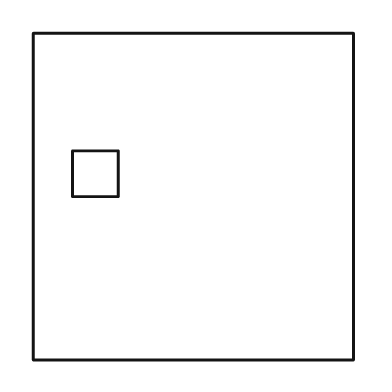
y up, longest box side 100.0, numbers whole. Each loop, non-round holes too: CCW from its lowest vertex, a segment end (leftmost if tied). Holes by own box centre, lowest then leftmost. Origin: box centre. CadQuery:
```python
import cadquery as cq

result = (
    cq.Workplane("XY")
    .moveTo(-49.0, -50.0)
    .lineTo(49.0, -50.0)
    .lineTo(49.0, 50.0)
    .lineTo(-49.0, 50.0)
    .close()
    .moveTo(-37.0, 0.0)
    .lineTo(-23.0, 0.0)
    .lineTo(-23.0, 14.0)
    .lineTo(-37.0, 14.0)
    .close()
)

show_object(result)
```